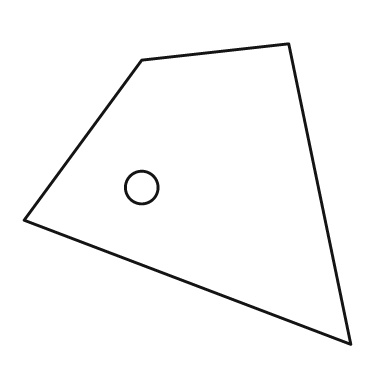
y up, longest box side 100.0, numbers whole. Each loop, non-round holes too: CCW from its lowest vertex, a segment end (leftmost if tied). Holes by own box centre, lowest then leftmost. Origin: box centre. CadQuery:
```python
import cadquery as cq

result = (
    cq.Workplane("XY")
    .moveTo(50.0, -46.0)
    .lineTo(31.0, 46.0)
    .lineTo(-14.0, 41.0)
    .lineTo(-50.0, -8.0)
    .close()
    .moveTo(-14.0, 2.0)
    .circle(5.0)
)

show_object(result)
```